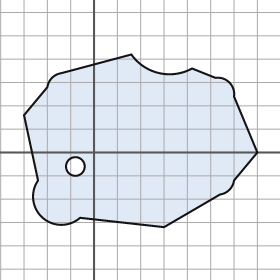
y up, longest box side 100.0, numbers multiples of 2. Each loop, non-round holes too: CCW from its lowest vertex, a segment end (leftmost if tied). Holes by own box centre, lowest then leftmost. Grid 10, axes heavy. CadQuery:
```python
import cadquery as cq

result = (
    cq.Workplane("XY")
    .moveTo(30.0, -32.0)
    .lineTo(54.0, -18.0)
    .threePointArc((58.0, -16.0), (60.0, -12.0))
    .lineTo(70.0, 0.0)
    .lineTo(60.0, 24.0)
    .threePointArc((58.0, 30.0), (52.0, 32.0))
    .lineTo(42.0, 36.0)
    .threePointArc((28.0, 34.0), (16.0, 42.0))
    .lineTo(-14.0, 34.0)
    .threePointArc((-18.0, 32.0), (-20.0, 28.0))
    .lineTo(-30.0, 16.0)
    .lineTo(-24.0, -12.0)
    .threePointArc((-22.0, -28.0), (-6.0, -28.0))
    .close()
    .moveTo(-8.0, -6.0)
    .circle(4.0)
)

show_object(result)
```